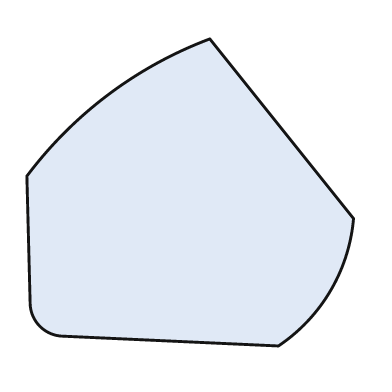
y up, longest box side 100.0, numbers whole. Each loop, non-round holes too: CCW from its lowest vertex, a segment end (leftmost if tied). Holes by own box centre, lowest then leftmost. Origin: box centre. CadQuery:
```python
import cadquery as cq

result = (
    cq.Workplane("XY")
    .moveTo(27.0, -47.0)
    .threePointArc((43.0, -30.0), (50.0, -8.0))
    .lineTo(6.0, 47.0)
    .threePointArc((-25.0, 30.0), (-50.0, 5.0))
    .lineTo(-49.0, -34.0)
    .threePointArc((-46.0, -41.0), (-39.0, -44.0))
    .close()
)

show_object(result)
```